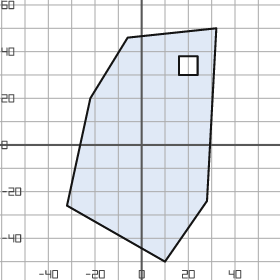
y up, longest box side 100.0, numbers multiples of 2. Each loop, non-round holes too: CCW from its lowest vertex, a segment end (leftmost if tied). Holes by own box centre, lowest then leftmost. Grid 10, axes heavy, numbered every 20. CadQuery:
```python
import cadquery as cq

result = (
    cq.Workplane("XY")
    .moveTo(10.0, -50.0)
    .lineTo(28.0, -24.0)
    .lineTo(32.0, 50.0)
    .lineTo(-6.0, 46.0)
    .lineTo(-22.0, 20.0)
    .lineTo(-32.0, -26.0)
    .close()
    .moveTo(16.0, 30.0)
    .lineTo(24.0, 30.0)
    .lineTo(24.0, 38.0)
    .lineTo(16.0, 38.0)
    .close()
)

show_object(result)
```